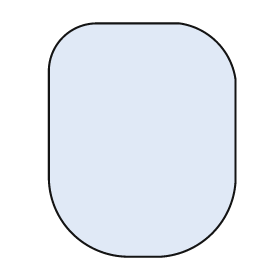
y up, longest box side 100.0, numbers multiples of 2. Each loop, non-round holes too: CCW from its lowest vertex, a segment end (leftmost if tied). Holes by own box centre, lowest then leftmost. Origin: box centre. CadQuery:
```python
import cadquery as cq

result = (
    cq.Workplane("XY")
    .moveTo(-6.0, -50.0)
    .lineTo(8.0, -50.0)
    .threePointArc((30.0, -40.0), (40.0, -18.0))
    .lineTo(40.0, 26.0)
    .threePointArc((32.0, 42.0), (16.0, 50.0))
    .lineTo(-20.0, 50.0)
    .threePointArc((-34.0, 44.0), (-40.0, 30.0))
    .lineTo(-40.0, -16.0)
    .threePointArc((-30.0, -40.0), (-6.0, -50.0))
    .close()
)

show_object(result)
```